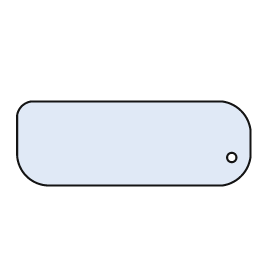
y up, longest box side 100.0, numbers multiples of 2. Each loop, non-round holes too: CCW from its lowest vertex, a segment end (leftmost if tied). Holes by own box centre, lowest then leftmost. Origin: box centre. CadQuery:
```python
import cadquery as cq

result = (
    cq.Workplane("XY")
    .moveTo(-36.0, -18.0)
    .lineTo(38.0, -18.0)
    .threePointArc((46.0, -14.0), (50.0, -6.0))
    .lineTo(50.0, 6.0)
    .threePointArc((46.0, 14.0), (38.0, 18.0))
    .lineTo(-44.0, 18.0)
    .threePointArc((-48.0, 16.0), (-50.0, 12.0))
    .lineTo(-50.0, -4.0)
    .threePointArc((-46.0, -14.0), (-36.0, -18.0))
    .close()
    .moveTo(42.0, -6.0)
    .circle(2.0)
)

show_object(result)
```